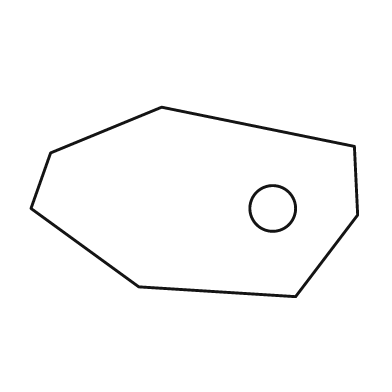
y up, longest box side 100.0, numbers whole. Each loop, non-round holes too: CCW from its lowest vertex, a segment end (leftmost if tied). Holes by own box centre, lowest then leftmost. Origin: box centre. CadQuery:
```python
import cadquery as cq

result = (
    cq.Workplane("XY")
    .moveTo(31.0, -29.0)
    .lineTo(50.0, -4.0)
    .lineTo(49.0, 17.0)
    .lineTo(-10.0, 29.0)
    .lineTo(-44.0, 15.0)
    .lineTo(-50.0, -2.0)
    .lineTo(-17.0, -26.0)
    .close()
    .moveTo(24.0, -2.0)
    .circle(7.0)
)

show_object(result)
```